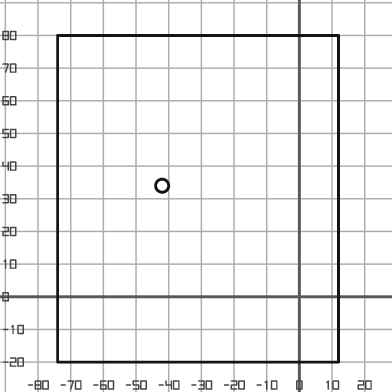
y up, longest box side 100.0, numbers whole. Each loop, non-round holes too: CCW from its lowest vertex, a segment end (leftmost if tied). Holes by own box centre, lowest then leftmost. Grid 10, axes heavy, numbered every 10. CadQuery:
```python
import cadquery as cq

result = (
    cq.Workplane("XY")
    .moveTo(-74.0, -20.0)
    .lineTo(12.0, -20.0)
    .lineTo(12.0, 80.0)
    .lineTo(-74.0, 80.0)
    .close()
    .moveTo(-42.0, 34.0)
    .circle(2.0)
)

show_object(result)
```